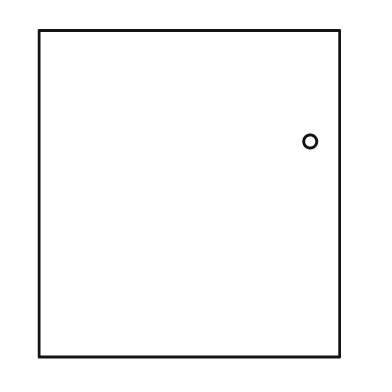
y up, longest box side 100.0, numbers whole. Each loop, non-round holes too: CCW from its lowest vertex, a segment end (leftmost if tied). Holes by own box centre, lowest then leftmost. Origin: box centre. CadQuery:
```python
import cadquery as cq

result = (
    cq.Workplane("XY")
    .moveTo(-46.0, -50.0)
    .lineTo(46.0, -50.0)
    .lineTo(46.0, 50.0)
    .lineTo(-46.0, 50.0)
    .close()
    .moveTo(37.0, 16.0)
    .circle(2.0)
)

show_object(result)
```